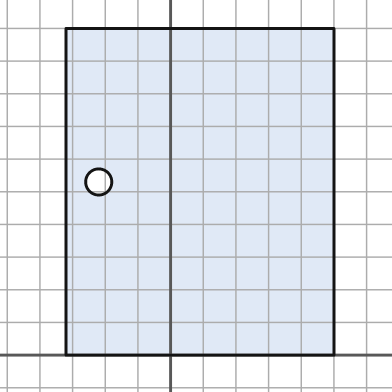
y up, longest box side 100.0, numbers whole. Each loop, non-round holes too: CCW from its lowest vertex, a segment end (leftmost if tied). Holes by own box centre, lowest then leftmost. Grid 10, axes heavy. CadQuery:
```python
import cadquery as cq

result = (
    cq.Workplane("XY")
    .moveTo(-32.0, 0.0)
    .lineTo(50.0, 0.0)
    .lineTo(50.0, 100.0)
    .lineTo(-32.0, 100.0)
    .close()
    .moveTo(-22.0, 53.0)
    .circle(4.0)
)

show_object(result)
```